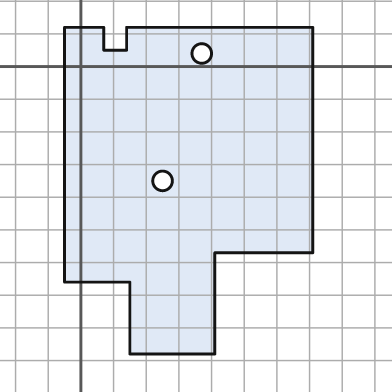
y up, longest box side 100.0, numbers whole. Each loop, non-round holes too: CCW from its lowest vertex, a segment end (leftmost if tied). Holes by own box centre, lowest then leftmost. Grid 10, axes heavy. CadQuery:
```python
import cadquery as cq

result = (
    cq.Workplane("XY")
    .moveTo(15.0, -88.0)
    .lineTo(41.0, -88.0)
    .lineTo(41.0, -57.0)
    .lineTo(71.0, -57.0)
    .lineTo(71.0, 12.0)
    .lineTo(14.0, 12.0)
    .lineTo(14.0, 5.0)
    .lineTo(7.0, 5.0)
    .lineTo(7.0, 12.0)
    .lineTo(-5.0, 12.0)
    .lineTo(-5.0, -66.0)
    .lineTo(15.0, -66.0)
    .close()
    .moveTo(25.0, -35.0)
    .circle(3.0)
    .moveTo(37.0, 4.0)
    .circle(3.0)
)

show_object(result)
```